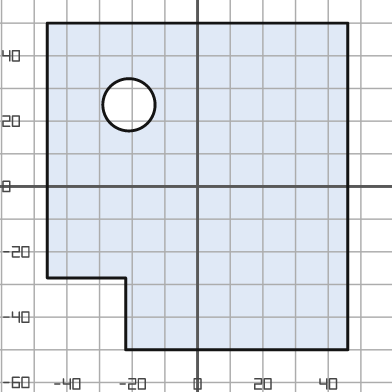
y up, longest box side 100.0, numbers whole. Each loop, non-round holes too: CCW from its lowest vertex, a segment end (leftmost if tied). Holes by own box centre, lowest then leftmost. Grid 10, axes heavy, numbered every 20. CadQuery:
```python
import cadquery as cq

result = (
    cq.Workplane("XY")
    .moveTo(-22.0, -50.0)
    .lineTo(46.0, -50.0)
    .lineTo(46.0, 50.0)
    .lineTo(-46.0, 50.0)
    .lineTo(-46.0, -28.0)
    .lineTo(-22.0, -28.0)
    .close()
    .moveTo(-21.0, 25.0)
    .circle(8.0)
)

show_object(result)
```